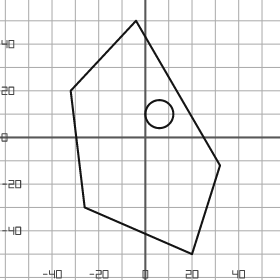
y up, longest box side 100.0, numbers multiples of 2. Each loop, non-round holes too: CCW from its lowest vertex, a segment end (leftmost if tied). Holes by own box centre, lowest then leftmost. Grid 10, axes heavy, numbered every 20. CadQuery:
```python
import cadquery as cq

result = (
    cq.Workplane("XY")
    .moveTo(20.0, -50.0)
    .lineTo(32.0, -12.0)
    .lineTo(-4.0, 50.0)
    .lineTo(-32.0, 20.0)
    .lineTo(-26.0, -30.0)
    .close()
    .moveTo(6.0, 10.0)
    .circle(6.0)
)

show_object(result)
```